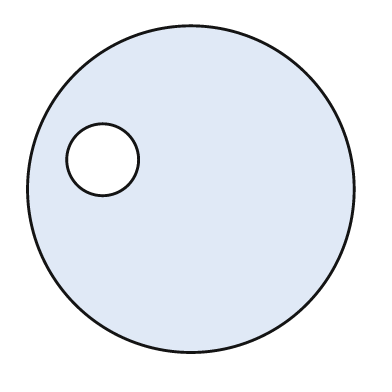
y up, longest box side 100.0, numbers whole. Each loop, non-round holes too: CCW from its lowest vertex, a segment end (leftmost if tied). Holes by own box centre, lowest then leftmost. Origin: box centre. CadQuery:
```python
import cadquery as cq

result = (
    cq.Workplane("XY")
    .moveTo(0.0, 0.0)
    .circle(50.0)
    .moveTo(-27.0, 9.0)
    .circle(11.0)
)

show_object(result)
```